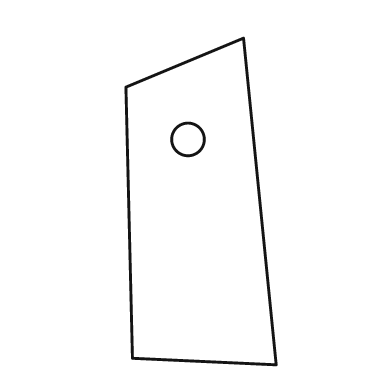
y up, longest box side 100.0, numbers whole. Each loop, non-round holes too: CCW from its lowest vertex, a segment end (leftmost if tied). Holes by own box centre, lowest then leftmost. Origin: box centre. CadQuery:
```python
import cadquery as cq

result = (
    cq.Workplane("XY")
    .moveTo(23.0, -50.0)
    .lineTo(13.0, 50.0)
    .lineTo(-23.0, 35.0)
    .lineTo(-21.0, -48.0)
    .close()
    .moveTo(-4.0, 19.0)
    .circle(5.0)
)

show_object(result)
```